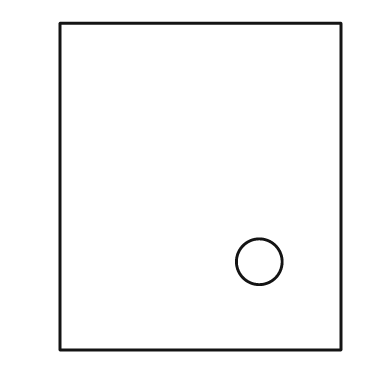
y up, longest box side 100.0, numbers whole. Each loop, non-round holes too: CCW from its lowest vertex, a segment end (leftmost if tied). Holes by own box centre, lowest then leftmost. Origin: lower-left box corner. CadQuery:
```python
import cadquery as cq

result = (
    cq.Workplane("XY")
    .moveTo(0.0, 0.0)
    .lineTo(86.0, 0.0)
    .lineTo(86.0, 100.0)
    .lineTo(0.0, 100.0)
    .close()
    .moveTo(61.0, 27.0)
    .circle(7.0)
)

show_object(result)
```